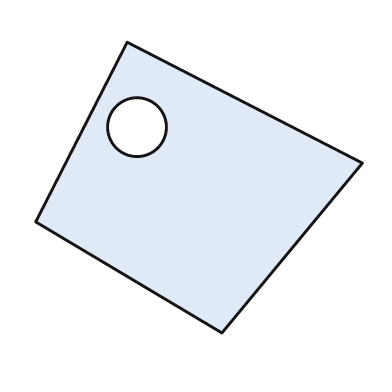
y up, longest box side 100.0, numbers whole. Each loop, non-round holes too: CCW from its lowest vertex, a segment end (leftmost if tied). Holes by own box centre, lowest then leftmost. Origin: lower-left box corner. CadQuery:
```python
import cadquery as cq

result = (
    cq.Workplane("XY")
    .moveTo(57.0, 0.0)
    .lineTo(100.0, 52.0)
    .lineTo(28.0, 89.0)
    .lineTo(0.0, 34.0)
    .close()
    .moveTo(31.0, 63.0)
    .circle(9.0)
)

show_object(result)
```